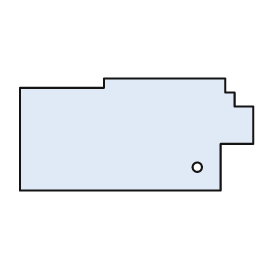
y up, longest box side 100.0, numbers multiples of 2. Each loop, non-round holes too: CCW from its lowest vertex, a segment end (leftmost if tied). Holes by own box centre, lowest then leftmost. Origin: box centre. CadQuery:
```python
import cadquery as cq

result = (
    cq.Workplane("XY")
    .moveTo(-50.0, -24.0)
    .lineTo(36.0, -24.0)
    .lineTo(36.0, -4.0)
    .lineTo(50.0, -4.0)
    .lineTo(50.0, 12.0)
    .lineTo(42.0, 12.0)
    .lineTo(42.0, 18.0)
    .lineTo(38.0, 18.0)
    .lineTo(38.0, 24.0)
    .lineTo(-14.0, 24.0)
    .lineTo(-14.0, 20.0)
    .lineTo(-50.0, 20.0)
    .close()
    .moveTo(26.0, -14.0)
    .circle(2.0)
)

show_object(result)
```